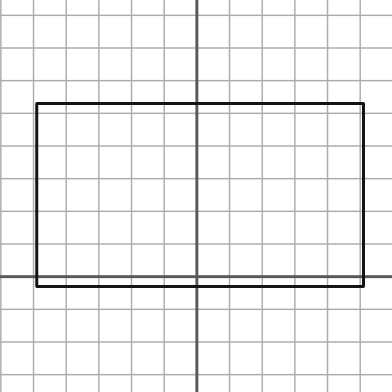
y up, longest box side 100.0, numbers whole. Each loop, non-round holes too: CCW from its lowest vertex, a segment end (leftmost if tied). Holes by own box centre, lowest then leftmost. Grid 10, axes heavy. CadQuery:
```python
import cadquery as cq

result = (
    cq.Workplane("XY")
    .moveTo(-49.0, -3.0)
    .lineTo(51.0, -3.0)
    .lineTo(51.0, 53.0)
    .lineTo(-49.0, 53.0)
    .close()
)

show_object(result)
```